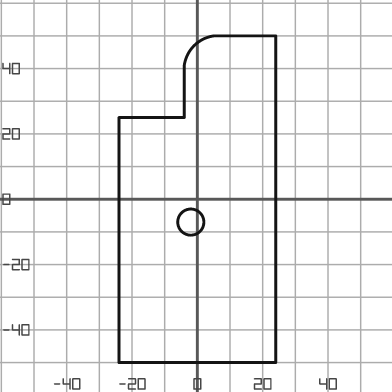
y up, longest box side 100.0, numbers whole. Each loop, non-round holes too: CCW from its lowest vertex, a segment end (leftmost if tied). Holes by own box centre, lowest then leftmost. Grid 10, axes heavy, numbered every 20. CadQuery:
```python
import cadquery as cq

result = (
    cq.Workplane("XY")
    .moveTo(-24.0, -50.0)
    .lineTo(24.0, -50.0)
    .lineTo(24.0, 50.0)
    .lineTo(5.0, 50.0)
    .threePointArc((-1.0, 47.0), (-4.0, 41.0))
    .lineTo(-4.0, 25.0)
    .lineTo(-24.0, 25.0)
    .close()
    .moveTo(-2.0, -7.0)
    .circle(4.0)
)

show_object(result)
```